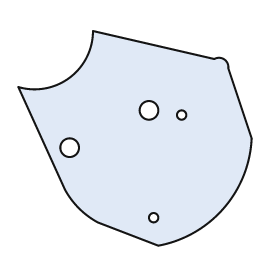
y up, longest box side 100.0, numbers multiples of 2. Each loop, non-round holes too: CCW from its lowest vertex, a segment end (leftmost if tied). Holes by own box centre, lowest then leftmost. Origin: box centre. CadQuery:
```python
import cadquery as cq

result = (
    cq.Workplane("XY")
    .moveTo(10.0, -46.0)
    .threePointArc((38.0, -30.0), (50.0, 0.0))
    .lineTo(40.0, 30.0)
    .threePointArc((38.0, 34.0), (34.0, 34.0))
    .lineTo(-18.0, 46.0)
    .threePointArc((-28.0, 26.0), (-50.0, 22.0))
    .lineTo(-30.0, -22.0)
    .threePointArc((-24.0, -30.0), (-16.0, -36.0))
    .close()
    .moveTo(8.0, -34.0)
    .circle(2.0)
    .moveTo(-28.0, -4.0)
    .circle(4.0)
    .moveTo(20.0, 10.0)
    .circle(2.0)
    .moveTo(6.0, 12.0)
    .circle(4.0)
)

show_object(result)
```